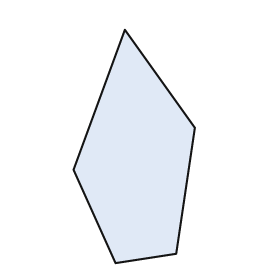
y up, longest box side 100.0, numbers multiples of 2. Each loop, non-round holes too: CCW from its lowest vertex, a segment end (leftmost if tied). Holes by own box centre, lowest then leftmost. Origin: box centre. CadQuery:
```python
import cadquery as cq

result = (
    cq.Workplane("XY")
    .moveTo(-8.0, -50.0)
    .lineTo(18.0, -46.0)
    .lineTo(26.0, 8.0)
    .lineTo(-4.0, 50.0)
    .lineTo(-26.0, -10.0)
    .close()
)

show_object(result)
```